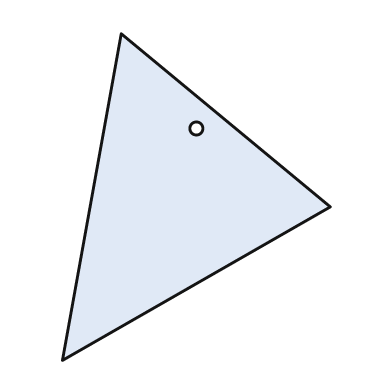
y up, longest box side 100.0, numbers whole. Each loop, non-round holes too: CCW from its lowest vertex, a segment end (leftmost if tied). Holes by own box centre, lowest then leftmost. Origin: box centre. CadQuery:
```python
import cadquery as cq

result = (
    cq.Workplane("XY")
    .moveTo(-41.0, -50.0)
    .lineTo(41.0, -3.0)
    .lineTo(-23.0, 50.0)
    .close()
    .moveTo(0.0, 21.0)
    .circle(2.0)
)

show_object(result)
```